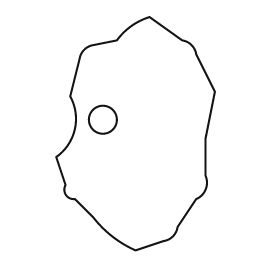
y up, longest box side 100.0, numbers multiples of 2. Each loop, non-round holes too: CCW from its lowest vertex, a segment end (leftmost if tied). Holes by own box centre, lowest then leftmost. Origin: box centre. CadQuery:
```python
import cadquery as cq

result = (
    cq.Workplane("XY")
    .moveTo(0.0, -50.0)
    .lineTo(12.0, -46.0)
    .threePointArc((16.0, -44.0), (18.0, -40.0))
    .lineTo(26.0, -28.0)
    .threePointArc((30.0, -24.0), (30.0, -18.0))
    .lineTo(30.0, -2.0)
    .lineTo(34.0, 18.0)
    .lineTo(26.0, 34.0)
    .threePointArc((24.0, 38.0), (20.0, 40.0))
    .lineTo(6.0, 50.0)
    .threePointArc((-2.0, 46.0), (-8.0, 40.0))
    .lineTo(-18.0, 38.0)
    .threePointArc((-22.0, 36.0), (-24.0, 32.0))
    .lineTo(-28.0, 16.0)
    .threePointArc((-26.0, 2.0), (-34.0, -10.0))
    .lineTo(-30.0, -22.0)
    .threePointArc((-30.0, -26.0), (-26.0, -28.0))
    .lineTo(-18.0, -36.0)
    .threePointArc((-10.0, -44.0), (0.0, -50.0))
    .close()
    .moveTo(-14.0, 6.0)
    .circle(6.0)
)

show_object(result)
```